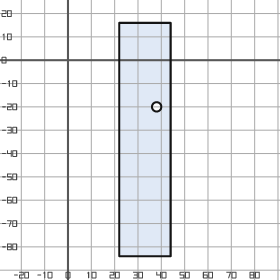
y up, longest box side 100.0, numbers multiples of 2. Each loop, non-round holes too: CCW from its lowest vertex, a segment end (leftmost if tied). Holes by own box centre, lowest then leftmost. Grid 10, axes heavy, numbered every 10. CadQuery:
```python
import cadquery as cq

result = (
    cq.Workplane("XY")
    .moveTo(22.0, -84.0)
    .lineTo(44.0, -84.0)
    .lineTo(44.0, 16.0)
    .lineTo(22.0, 16.0)
    .close()
    .moveTo(38.0, -20.0)
    .circle(2.0)
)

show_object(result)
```